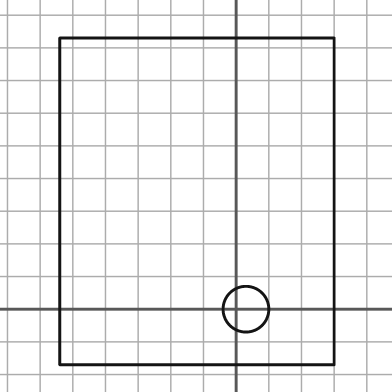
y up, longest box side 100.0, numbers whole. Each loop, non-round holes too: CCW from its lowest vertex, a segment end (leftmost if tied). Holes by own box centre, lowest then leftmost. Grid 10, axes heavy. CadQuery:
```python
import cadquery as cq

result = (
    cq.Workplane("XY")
    .moveTo(-54.0, -17.0)
    .lineTo(30.0, -17.0)
    .lineTo(30.0, 83.0)
    .lineTo(-54.0, 83.0)
    .close()
    .moveTo(3.0, 0.0)
    .circle(7.0)
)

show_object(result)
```